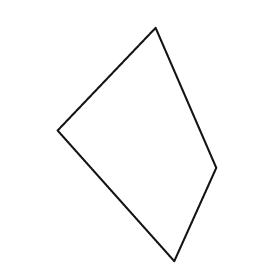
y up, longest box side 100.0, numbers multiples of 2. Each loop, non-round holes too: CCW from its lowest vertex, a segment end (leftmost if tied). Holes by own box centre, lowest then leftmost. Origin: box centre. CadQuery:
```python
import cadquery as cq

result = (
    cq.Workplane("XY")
    .moveTo(16.0, -50.0)
    .lineTo(34.0, -10.0)
    .lineTo(8.0, 50.0)
    .lineTo(-34.0, 6.0)
    .close()
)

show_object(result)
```